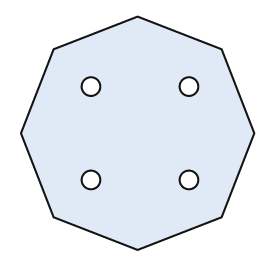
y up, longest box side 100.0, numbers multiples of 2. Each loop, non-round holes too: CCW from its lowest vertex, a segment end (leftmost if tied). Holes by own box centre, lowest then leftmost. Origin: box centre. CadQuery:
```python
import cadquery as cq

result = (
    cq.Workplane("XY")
    .moveTo(0.0, -50.0)
    .lineTo(36.0, -36.0)
    .lineTo(50.0, 0.0)
    .lineTo(36.0, 36.0)
    .lineTo(0.0, 50.0)
    .lineTo(-36.0, 36.0)
    .lineTo(-50.0, 0.0)
    .lineTo(-36.0, -36.0)
    .close()
    .moveTo(-20.0, -20.0)
    .circle(4.0)
    .moveTo(22.0, -20.0)
    .circle(4.0)
    .moveTo(-20.0, 20.0)
    .circle(4.0)
    .moveTo(22.0, 20.0)
    .circle(4.0)
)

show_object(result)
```